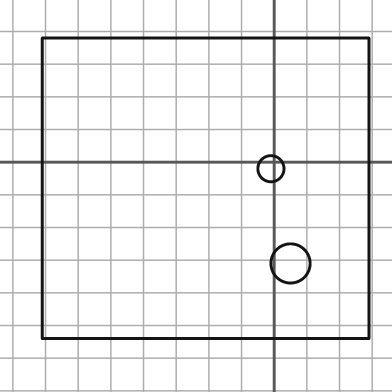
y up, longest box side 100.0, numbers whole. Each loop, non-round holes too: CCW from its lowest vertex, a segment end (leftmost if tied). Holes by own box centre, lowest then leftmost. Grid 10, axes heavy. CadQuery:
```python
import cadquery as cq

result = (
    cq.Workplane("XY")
    .moveTo(-71.0, -54.0)
    .lineTo(29.0, -54.0)
    .lineTo(29.0, 38.0)
    .lineTo(-71.0, 38.0)
    .close()
    .moveTo(5.0, -31.0)
    .circle(6.0)
    .moveTo(-1.0, -2.0)
    .circle(4.0)
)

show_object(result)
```